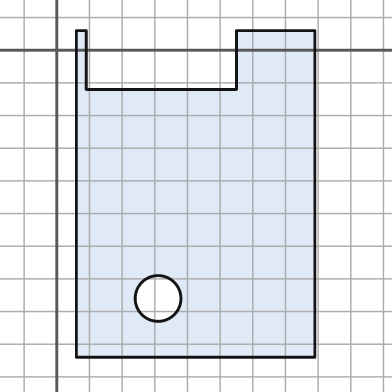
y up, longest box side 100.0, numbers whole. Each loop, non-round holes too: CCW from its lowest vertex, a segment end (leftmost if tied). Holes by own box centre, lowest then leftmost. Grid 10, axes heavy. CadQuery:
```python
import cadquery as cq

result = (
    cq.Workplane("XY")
    .moveTo(6.0, -94.0)
    .lineTo(79.0, -94.0)
    .lineTo(79.0, 6.0)
    .lineTo(55.0, 6.0)
    .lineTo(55.0, -12.0)
    .lineTo(9.0, -12.0)
    .lineTo(9.0, 6.0)
    .lineTo(6.0, 6.0)
    .close()
    .moveTo(31.0, -76.0)
    .circle(7.0)
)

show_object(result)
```